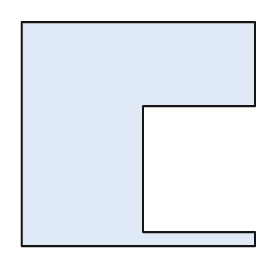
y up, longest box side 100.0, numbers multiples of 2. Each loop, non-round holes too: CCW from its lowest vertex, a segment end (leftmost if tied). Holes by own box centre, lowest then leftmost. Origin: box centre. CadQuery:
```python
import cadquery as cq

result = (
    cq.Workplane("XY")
    .moveTo(-50.0, -48.0)
    .lineTo(50.0, -48.0)
    .lineTo(50.0, -42.0)
    .lineTo(2.0, -42.0)
    .lineTo(2.0, 12.0)
    .lineTo(50.0, 12.0)
    .lineTo(50.0, 48.0)
    .lineTo(-50.0, 48.0)
    .close()
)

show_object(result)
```